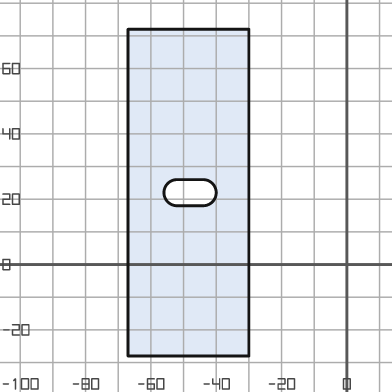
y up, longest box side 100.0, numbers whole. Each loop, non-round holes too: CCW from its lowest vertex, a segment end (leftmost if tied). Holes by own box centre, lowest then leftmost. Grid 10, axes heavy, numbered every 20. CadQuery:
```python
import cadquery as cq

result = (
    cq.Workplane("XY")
    .moveTo(-67.0, -28.0)
    .lineTo(-30.0, -28.0)
    .lineTo(-30.0, 72.0)
    .lineTo(-67.0, 72.0)
    .close()
    .moveTo(-52.0, 18.0)
    .lineTo(-44.0, 18.0)
    .threePointArc((-40.0, 22.0), (-44.0, 26.0))
    .lineTo(-52.0, 26.0)
    .threePointArc((-56.0, 22.0), (-52.0, 18.0))
    .close()
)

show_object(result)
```